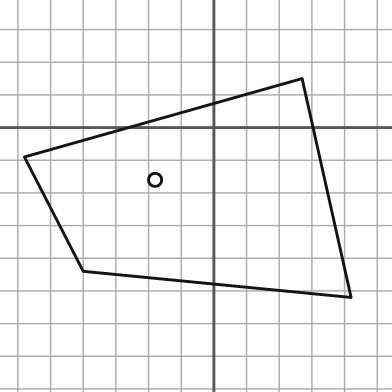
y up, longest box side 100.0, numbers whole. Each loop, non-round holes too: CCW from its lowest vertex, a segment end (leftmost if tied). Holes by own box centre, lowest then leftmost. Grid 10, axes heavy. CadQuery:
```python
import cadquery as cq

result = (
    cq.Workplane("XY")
    .moveTo(42.0, -52.0)
    .lineTo(27.0, 15.0)
    .lineTo(-58.0, -9.0)
    .lineTo(-40.0, -44.0)
    .close()
    .moveTo(-18.0, -16.0)
    .circle(2.0)
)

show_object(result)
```